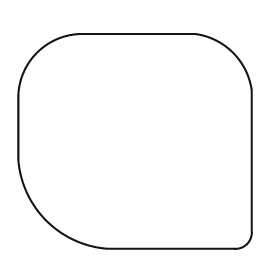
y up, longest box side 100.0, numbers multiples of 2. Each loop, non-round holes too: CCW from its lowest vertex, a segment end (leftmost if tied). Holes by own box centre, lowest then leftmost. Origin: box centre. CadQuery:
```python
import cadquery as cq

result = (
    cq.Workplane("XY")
    .moveTo(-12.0, -46.0)
    .lineTo(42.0, -46.0)
    .threePointArc((48.0, -44.0), (50.0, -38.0))
    .lineTo(50.0, 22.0)
    .threePointArc((42.0, 38.0), (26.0, 46.0))
    .lineTo(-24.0, 46.0)
    .threePointArc((-42.0, 38.0), (-50.0, 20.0))
    .lineTo(-50.0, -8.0)
    .threePointArc((-38.0, -34.0), (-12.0, -46.0))
    .close()
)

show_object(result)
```